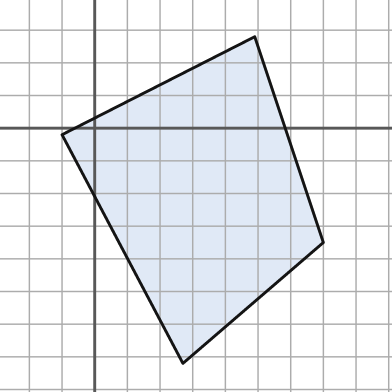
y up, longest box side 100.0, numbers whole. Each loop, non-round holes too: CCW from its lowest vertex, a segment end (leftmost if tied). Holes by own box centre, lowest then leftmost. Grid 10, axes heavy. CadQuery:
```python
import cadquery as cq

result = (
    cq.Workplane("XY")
    .moveTo(27.0, -72.0)
    .lineTo(70.0, -35.0)
    .lineTo(49.0, 28.0)
    .lineTo(-10.0, -2.0)
    .close()
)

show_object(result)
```